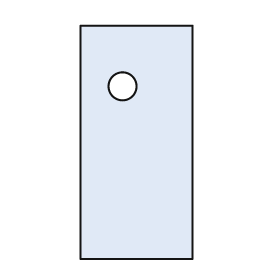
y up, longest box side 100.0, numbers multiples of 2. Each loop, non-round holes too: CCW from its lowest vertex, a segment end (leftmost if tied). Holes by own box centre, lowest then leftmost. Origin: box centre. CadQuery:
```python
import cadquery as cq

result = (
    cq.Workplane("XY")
    .moveTo(-24.0, -50.0)
    .lineTo(24.0, -50.0)
    .lineTo(24.0, 50.0)
    .lineTo(-24.0, 50.0)
    .close()
    .moveTo(-6.0, 24.0)
    .circle(6.0)
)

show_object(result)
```